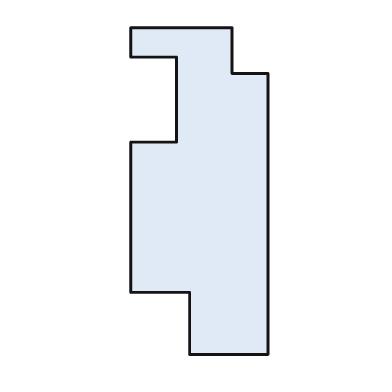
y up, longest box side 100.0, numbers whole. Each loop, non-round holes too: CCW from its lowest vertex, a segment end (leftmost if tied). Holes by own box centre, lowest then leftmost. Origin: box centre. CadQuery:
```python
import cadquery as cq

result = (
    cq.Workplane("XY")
    .moveTo(-3.0, -50.0)
    .lineTo(21.0, -50.0)
    .lineTo(21.0, 36.0)
    .lineTo(10.0, 36.0)
    .lineTo(10.0, 50.0)
    .lineTo(-21.0, 50.0)
    .lineTo(-21.0, 41.0)
    .lineTo(-7.0, 41.0)
    .lineTo(-7.0, 15.0)
    .lineTo(-21.0, 15.0)
    .lineTo(-21.0, -31.0)
    .lineTo(-3.0, -31.0)
    .close()
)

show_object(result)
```